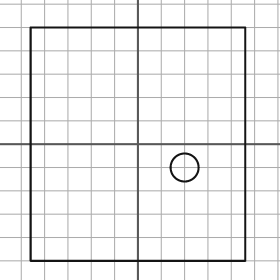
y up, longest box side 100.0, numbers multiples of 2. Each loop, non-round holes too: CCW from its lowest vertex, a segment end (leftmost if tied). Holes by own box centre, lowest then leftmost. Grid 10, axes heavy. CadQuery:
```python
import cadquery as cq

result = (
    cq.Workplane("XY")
    .moveTo(-46.0, -50.0)
    .lineTo(46.0, -50.0)
    .lineTo(46.0, 50.0)
    .lineTo(-46.0, 50.0)
    .close()
    .moveTo(20.0, -10.0)
    .circle(6.0)
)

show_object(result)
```